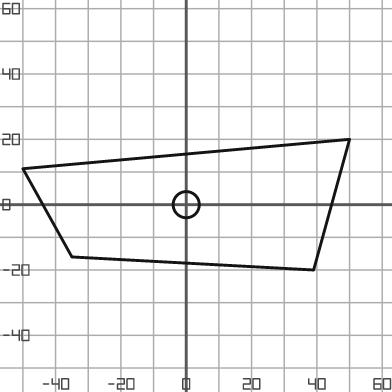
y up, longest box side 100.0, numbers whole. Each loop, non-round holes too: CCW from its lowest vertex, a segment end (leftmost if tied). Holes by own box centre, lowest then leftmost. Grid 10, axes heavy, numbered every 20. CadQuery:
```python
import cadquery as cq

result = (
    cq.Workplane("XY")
    .moveTo(39.0, -20.0)
    .lineTo(50.0, 20.0)
    .lineTo(-50.0, 11.0)
    .lineTo(-35.0, -16.0)
    .close()
    .moveTo(0.0, 0.0)
    .circle(4.0)
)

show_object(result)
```